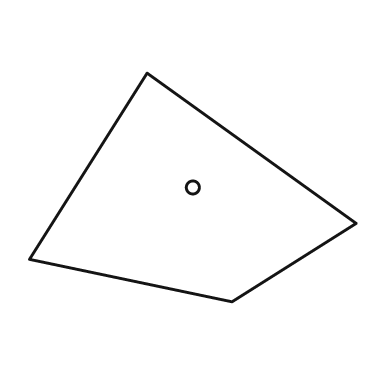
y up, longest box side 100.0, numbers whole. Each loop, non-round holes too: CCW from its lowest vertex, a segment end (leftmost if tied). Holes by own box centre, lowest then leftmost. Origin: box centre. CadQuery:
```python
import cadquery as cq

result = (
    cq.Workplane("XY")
    .moveTo(12.0, -35.0)
    .lineTo(50.0, -11.0)
    .lineTo(-14.0, 35.0)
    .lineTo(-50.0, -22.0)
    .close()
    .moveTo(0.0, 0.0)
    .circle(2.0)
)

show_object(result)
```